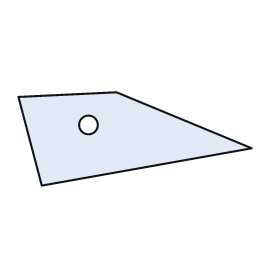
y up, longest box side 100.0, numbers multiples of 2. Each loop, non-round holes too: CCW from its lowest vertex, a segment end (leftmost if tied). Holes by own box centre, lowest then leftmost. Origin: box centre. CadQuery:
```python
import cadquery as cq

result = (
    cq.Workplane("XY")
    .moveTo(-40.0, -20.0)
    .lineTo(50.0, -4.0)
    .lineTo(-8.0, 20.0)
    .lineTo(-50.0, 18.0)
    .close()
    .moveTo(-20.0, 6.0)
    .circle(4.0)
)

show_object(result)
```